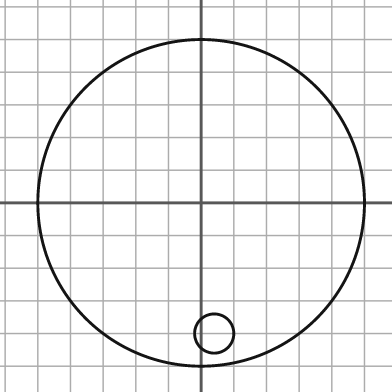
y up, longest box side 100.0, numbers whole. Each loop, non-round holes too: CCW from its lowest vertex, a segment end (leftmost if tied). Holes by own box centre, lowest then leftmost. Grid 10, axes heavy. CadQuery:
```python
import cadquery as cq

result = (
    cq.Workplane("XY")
    .moveTo(0.0, 0.0)
    .circle(50.0)
    .moveTo(4.0, -40.0)
    .circle(6.0)
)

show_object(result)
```